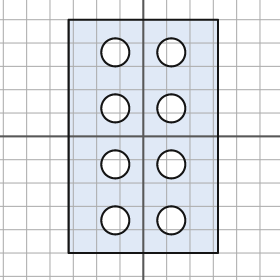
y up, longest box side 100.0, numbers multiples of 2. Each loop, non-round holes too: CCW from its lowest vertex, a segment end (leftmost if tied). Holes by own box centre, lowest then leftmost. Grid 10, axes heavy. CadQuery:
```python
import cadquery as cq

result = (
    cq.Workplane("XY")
    .moveTo(-32.0, -50.0)
    .lineTo(32.0, -50.0)
    .lineTo(32.0, 50.0)
    .lineTo(-32.0, 50.0)
    .close()
    .moveTo(-12.0, -36.0)
    .circle(6.0)
    .moveTo(12.0, -36.0)
    .circle(6.0)
    .moveTo(-12.0, -12.0)
    .circle(6.0)
    .moveTo(12.0, -12.0)
    .circle(6.0)
    .moveTo(-12.0, 12.0)
    .circle(6.0)
    .moveTo(12.0, 12.0)
    .circle(6.0)
    .moveTo(-12.0, 36.0)
    .circle(6.0)
    .moveTo(12.0, 36.0)
    .circle(6.0)
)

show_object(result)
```